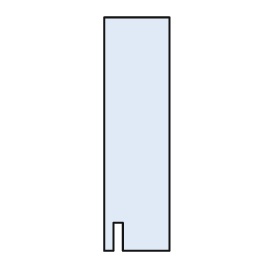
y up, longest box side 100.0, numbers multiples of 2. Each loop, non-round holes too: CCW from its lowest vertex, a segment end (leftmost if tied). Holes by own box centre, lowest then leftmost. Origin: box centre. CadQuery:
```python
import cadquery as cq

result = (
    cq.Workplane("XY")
    .moveTo(-14.0, -50.0)
    .lineTo(-10.0, -50.0)
    .lineTo(-10.0, -38.0)
    .lineTo(-6.0, -38.0)
    .lineTo(-6.0, -50.0)
    .lineTo(14.0, -50.0)
    .lineTo(14.0, 50.0)
    .lineTo(-14.0, 50.0)
    .close()
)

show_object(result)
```